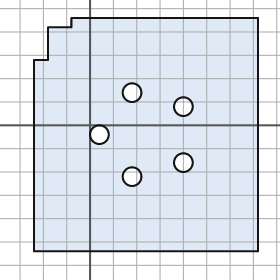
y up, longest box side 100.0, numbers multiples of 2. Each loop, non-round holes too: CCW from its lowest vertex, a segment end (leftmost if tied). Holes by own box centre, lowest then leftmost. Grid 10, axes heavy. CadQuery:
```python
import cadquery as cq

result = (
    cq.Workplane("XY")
    .moveTo(-24.0, -54.0)
    .lineTo(72.0, -54.0)
    .lineTo(72.0, 46.0)
    .lineTo(-8.0, 46.0)
    .lineTo(-8.0, 42.0)
    .lineTo(-18.0, 42.0)
    .lineTo(-18.0, 28.0)
    .lineTo(-24.0, 28.0)
    .close()
    .moveTo(18.0, -22.0)
    .circle(4.0)
    .moveTo(40.0, -16.0)
    .circle(4.0)
    .moveTo(4.0, -4.0)
    .circle(4.0)
    .moveTo(40.0, 8.0)
    .circle(4.0)
    .moveTo(18.0, 14.0)
    .circle(4.0)
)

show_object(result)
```